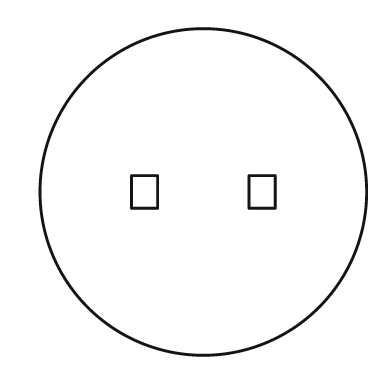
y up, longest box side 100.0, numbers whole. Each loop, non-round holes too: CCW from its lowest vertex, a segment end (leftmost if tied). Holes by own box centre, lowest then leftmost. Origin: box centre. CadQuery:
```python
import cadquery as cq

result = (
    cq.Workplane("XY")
    .moveTo(0.0, 0.0)
    .circle(50.0)
    .moveTo(-22.0, -5.0)
    .lineTo(-14.0, -5.0)
    .lineTo(-14.0, 5.0)
    .lineTo(-22.0, 5.0)
    .close()
    .moveTo(14.0, -5.0)
    .lineTo(22.0, -5.0)
    .lineTo(22.0, 5.0)
    .lineTo(14.0, 5.0)
    .close()
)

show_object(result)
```